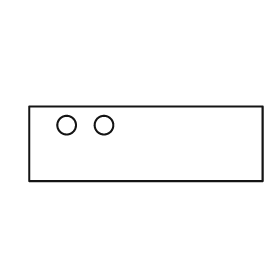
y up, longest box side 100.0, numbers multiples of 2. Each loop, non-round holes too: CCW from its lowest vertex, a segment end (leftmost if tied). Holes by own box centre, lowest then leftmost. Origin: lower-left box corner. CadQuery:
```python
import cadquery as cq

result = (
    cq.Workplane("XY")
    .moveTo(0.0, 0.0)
    .lineTo(100.0, 0.0)
    .lineTo(100.0, 32.0)
    .lineTo(0.0, 32.0)
    .close()
    .moveTo(16.0, 24.0)
    .circle(4.0)
    .moveTo(32.0, 24.0)
    .circle(4.0)
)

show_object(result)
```